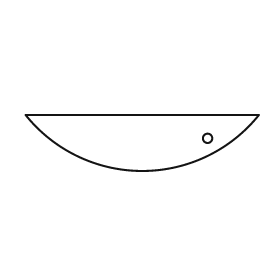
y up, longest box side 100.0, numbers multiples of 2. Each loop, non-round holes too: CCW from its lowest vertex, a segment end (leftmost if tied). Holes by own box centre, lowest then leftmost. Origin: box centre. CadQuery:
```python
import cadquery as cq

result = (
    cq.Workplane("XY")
    .moveTo(-50.0, 12.0)
    .threePointArc((0.0, -12.0), (50.0, 12.0))
    .close()
    .moveTo(28.0, 2.0)
    .circle(2.0)
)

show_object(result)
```